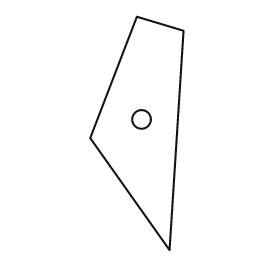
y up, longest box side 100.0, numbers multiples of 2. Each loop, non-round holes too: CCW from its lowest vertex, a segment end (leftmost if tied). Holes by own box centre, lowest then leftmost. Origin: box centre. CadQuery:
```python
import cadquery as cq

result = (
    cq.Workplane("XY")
    .moveTo(14.0, -50.0)
    .lineTo(20.0, 44.0)
    .lineTo(0.0, 50.0)
    .lineTo(-20.0, -2.0)
    .close()
    .moveTo(2.0, 6.0)
    .circle(4.0)
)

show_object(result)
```